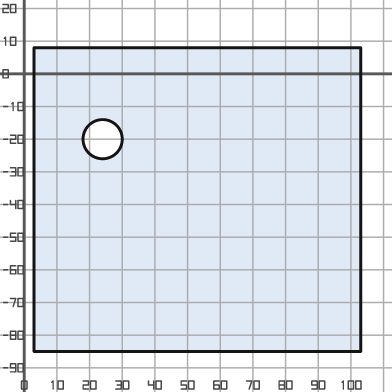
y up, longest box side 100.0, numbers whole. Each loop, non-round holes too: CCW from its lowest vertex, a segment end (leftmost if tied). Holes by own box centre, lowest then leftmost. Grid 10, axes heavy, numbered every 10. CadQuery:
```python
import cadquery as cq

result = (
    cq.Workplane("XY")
    .moveTo(3.0, -85.0)
    .lineTo(103.0, -85.0)
    .lineTo(103.0, 8.0)
    .lineTo(3.0, 8.0)
    .close()
    .moveTo(24.0, -20.0)
    .circle(6.0)
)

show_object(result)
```